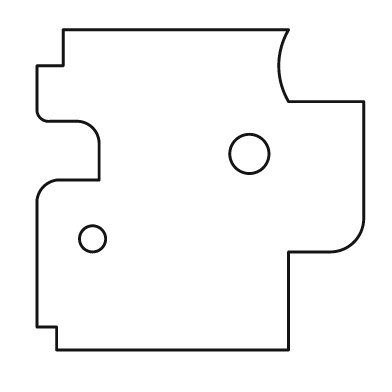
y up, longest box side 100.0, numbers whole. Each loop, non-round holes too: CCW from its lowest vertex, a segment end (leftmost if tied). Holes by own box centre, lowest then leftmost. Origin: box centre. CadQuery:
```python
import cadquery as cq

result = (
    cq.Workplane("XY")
    .moveTo(-44.0, -49.0)
    .lineTo(27.0, -49.0)
    .lineTo(27.0, -19.0)
    .lineTo(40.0, -19.0)
    .threePointArc((47.0, -16.0), (50.0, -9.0))
    .lineTo(50.0, 27.0)
    .lineTo(27.0, 27.0)
    .threePointArc((24.0, 38.0), (27.0, 49.0))
    .lineTo(-42.0, 49.0)
    .lineTo(-42.0, 38.0)
    .lineTo(-50.0, 38.0)
    .lineTo(-50.0, 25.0)
    .threePointArc((-49.0, 22.0), (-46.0, 21.0))
    .lineTo(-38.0, 21.0)
    .threePointArc((-33.0, 19.0), (-31.0, 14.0))
    .lineTo(-31.0, 3.0)
    .lineTo(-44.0, 3.0)
    .threePointArc((-48.0, 1.0), (-50.0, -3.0))
    .lineTo(-50.0, -42.0)
    .lineTo(-44.0, -42.0)
    .close()
    .moveTo(-33.0, -15.0)
    .circle(4.0)
    .moveTo(15.0, 11.0)
    .circle(6.0)
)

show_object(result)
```